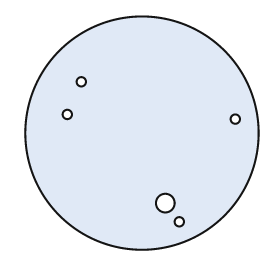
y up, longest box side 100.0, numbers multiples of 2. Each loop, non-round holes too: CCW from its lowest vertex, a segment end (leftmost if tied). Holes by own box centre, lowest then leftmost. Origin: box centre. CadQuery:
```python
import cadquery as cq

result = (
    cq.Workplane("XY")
    .moveTo(0.0, 0.0)
    .circle(50.0)
    .moveTo(16.0, -38.0)
    .circle(2.0)
    .moveTo(10.0, -30.0)
    .circle(4.0)
    .moveTo(40.0, 6.0)
    .circle(2.0)
    .moveTo(-32.0, 8.0)
    .circle(2.0)
    .moveTo(-26.0, 22.0)
    .circle(2.0)
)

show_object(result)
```